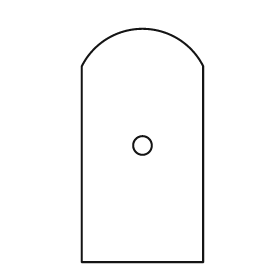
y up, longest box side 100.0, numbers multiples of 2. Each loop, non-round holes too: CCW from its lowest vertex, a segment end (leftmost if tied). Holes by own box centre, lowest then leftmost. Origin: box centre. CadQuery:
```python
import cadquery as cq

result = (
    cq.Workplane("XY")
    .moveTo(-26.0, -50.0)
    .lineTo(26.0, -50.0)
    .lineTo(26.0, 34.0)
    .threePointArc((0.0, 50.0), (-26.0, 34.0))
    .close()
    .moveTo(0.0, 0.0)
    .circle(4.0)
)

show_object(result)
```